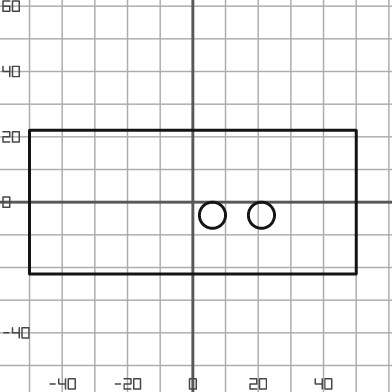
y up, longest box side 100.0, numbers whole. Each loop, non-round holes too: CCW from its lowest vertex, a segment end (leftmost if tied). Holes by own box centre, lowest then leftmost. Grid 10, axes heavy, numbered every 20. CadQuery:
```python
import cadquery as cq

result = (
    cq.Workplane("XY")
    .moveTo(-50.0, -22.0)
    .lineTo(50.0, -22.0)
    .lineTo(50.0, 22.0)
    .lineTo(-50.0, 22.0)
    .close()
    .moveTo(6.0, -4.0)
    .circle(4.0)
    .moveTo(21.0, -4.0)
    .circle(4.0)
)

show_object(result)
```